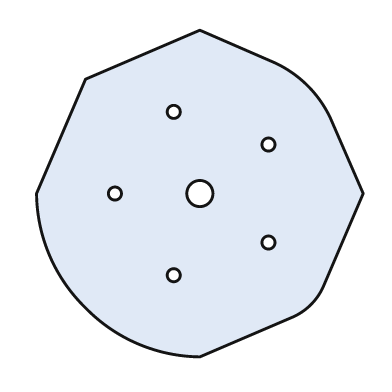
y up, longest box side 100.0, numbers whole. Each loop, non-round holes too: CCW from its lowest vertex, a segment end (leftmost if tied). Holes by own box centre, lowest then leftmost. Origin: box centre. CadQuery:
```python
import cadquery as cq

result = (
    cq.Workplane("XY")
    .moveTo(0.0, -50.0)
    .lineTo(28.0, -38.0)
    .threePointArc((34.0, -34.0), (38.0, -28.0))
    .lineTo(50.0, 0.0)
    .lineTo(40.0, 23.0)
    .threePointArc((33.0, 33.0), (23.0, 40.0))
    .lineTo(0.0, 50.0)
    .lineTo(-35.0, 35.0)
    .lineTo(-50.0, 0.0)
    .threePointArc((-46.0, -19.0), (-35.0, -35.0))
    .threePointArc((-19.0, -46.0), (0.0, -50.0))
    .close()
    .moveTo(-8.0, -25.0)
    .circle(2.0)
    .moveTo(21.0, -15.0)
    .circle(2.0)
    .moveTo(-26.0, 0.0)
    .circle(2.0)
    .moveTo(0.0, 0.0)
    .circle(4.0)
    .moveTo(21.0, 15.0)
    .circle(2.0)
    .moveTo(-8.0, 25.0)
    .circle(2.0)
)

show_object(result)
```